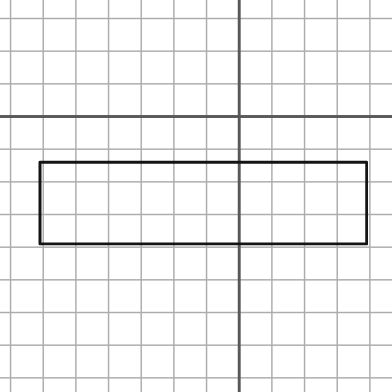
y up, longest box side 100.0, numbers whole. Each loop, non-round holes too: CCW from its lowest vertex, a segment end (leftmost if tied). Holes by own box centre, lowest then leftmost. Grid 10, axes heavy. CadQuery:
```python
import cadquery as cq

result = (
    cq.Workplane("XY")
    .moveTo(-61.0, -39.0)
    .lineTo(39.0, -39.0)
    .lineTo(39.0, -14.0)
    .lineTo(-61.0, -14.0)
    .close()
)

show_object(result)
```